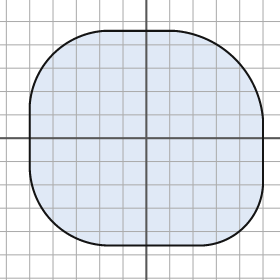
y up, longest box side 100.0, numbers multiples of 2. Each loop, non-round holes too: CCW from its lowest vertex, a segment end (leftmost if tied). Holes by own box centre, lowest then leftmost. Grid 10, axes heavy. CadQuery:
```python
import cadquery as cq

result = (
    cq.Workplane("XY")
    .moveTo(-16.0, -46.0)
    .lineTo(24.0, -46.0)
    .threePointArc((42.0, -38.0), (50.0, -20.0))
    .lineTo(50.0, 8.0)
    .threePointArc((38.0, 34.0), (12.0, 46.0))
    .lineTo(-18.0, 46.0)
    .threePointArc((-40.0, 36.0), (-50.0, 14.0))
    .lineTo(-50.0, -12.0)
    .threePointArc((-40.0, -36.0), (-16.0, -46.0))
    .close()
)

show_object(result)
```